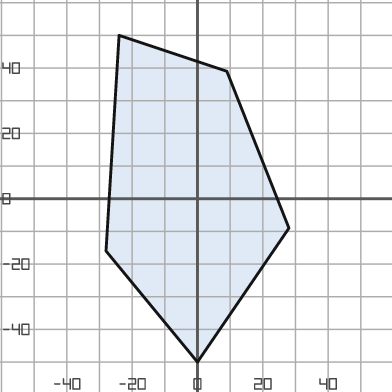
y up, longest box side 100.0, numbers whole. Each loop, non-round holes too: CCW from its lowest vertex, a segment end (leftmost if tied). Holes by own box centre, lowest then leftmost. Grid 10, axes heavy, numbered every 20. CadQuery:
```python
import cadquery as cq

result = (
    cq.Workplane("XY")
    .moveTo(0.0, -50.0)
    .lineTo(28.0, -9.0)
    .lineTo(9.0, 39.0)
    .lineTo(-24.0, 50.0)
    .lineTo(-28.0, -16.0)
    .close()
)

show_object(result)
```